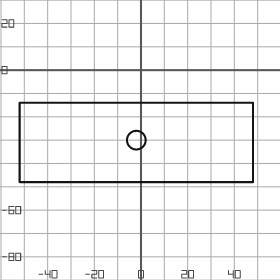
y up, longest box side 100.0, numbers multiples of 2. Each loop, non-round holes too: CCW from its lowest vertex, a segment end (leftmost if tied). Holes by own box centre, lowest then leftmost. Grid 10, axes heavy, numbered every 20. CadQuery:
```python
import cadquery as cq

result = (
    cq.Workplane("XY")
    .moveTo(-52.0, -48.0)
    .lineTo(48.0, -48.0)
    .lineTo(48.0, -14.0)
    .lineTo(-52.0, -14.0)
    .close()
    .moveTo(-2.0, -30.0)
    .circle(4.0)
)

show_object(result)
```